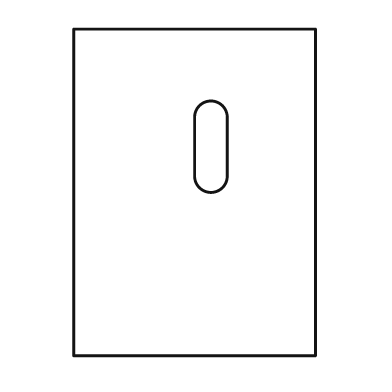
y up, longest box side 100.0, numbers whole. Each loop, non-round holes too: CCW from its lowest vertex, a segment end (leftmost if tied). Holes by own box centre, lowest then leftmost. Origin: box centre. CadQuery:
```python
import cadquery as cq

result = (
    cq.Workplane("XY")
    .moveTo(-37.0, -50.0)
    .lineTo(37.0, -50.0)
    .lineTo(37.0, 50.0)
    .lineTo(-37.0, 50.0)
    .close()
    .moveTo(0.0, 5.0)
    .threePointArc((5.0, 0.0), (10.0, 5.0))
    .lineTo(10.0, 23.0)
    .threePointArc((5.0, 28.0), (0.0, 23.0))
    .close()
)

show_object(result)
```